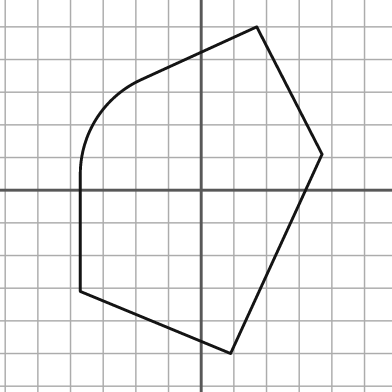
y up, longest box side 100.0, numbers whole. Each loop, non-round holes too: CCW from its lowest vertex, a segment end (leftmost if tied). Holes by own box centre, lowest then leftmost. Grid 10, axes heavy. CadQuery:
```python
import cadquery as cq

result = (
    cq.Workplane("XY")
    .moveTo(9.0, -50.0)
    .lineTo(37.0, 11.0)
    .lineTo(17.0, 50.0)
    .lineTo(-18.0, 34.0)
    .threePointArc((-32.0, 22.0), (-37.0, 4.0))
    .lineTo(-37.0, -31.0)
    .close()
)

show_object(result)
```